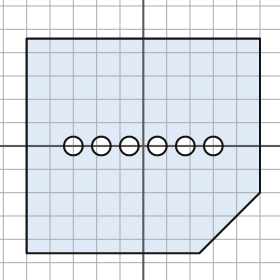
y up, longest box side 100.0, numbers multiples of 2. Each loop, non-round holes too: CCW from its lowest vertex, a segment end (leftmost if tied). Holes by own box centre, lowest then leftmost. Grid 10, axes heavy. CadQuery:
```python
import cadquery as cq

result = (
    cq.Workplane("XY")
    .moveTo(-50.0, -46.0)
    .lineTo(24.0, -46.0)
    .lineTo(50.0, -20.0)
    .lineTo(50.0, 46.0)
    .lineTo(-50.0, 46.0)
    .close()
    .moveTo(-30.0, 0.0)
    .circle(4.0)
    .moveTo(-18.0, 0.0)
    .circle(4.0)
    .moveTo(-6.0, 0.0)
    .circle(4.0)
    .moveTo(6.0, 0.0)
    .circle(4.0)
    .moveTo(18.0, 0.0)
    .circle(4.0)
    .moveTo(30.0, 0.0)
    .circle(4.0)
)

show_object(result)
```